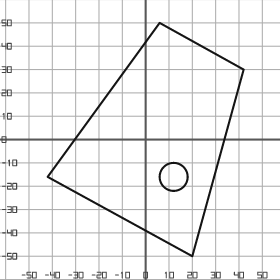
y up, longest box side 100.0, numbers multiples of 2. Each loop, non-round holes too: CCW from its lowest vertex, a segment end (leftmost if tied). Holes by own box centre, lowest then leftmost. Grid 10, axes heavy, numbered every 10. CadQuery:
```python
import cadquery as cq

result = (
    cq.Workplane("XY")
    .moveTo(20.0, -50.0)
    .lineTo(42.0, 30.0)
    .lineTo(6.0, 50.0)
    .lineTo(-42.0, -16.0)
    .close()
    .moveTo(12.0, -16.0)
    .circle(6.0)
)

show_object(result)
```